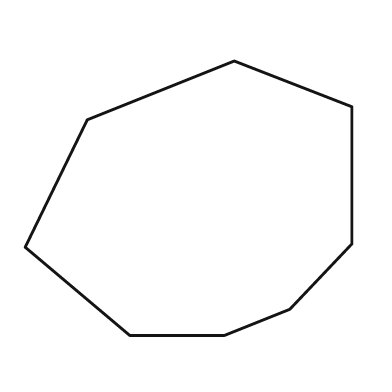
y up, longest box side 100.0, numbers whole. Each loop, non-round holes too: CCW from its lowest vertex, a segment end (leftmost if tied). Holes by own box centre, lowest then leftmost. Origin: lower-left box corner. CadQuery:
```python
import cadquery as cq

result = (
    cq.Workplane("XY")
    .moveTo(32.0, 0.0)
    .lineTo(61.0, 0.0)
    .lineTo(81.0, 8.0)
    .lineTo(100.0, 28.0)
    .lineTo(100.0, 70.0)
    .lineTo(64.0, 84.0)
    .lineTo(19.0, 66.0)
    .lineTo(0.0, 27.0)
    .close()
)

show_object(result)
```